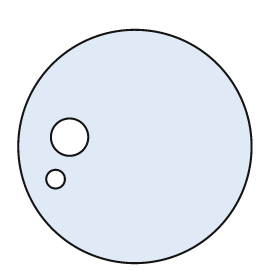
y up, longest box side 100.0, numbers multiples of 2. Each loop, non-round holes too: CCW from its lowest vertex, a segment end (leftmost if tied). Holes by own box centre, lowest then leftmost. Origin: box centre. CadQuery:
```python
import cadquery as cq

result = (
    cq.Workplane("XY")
    .moveTo(0.0, 0.0)
    .circle(50.0)
    .moveTo(-34.0, -14.0)
    .circle(4.0)
    .moveTo(-28.0, 4.0)
    .circle(8.0)
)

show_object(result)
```